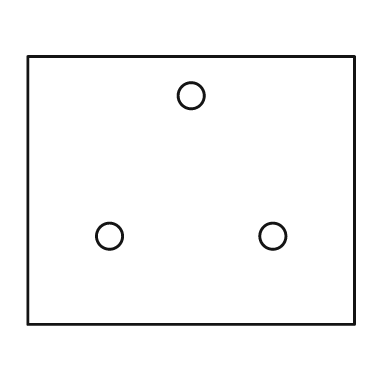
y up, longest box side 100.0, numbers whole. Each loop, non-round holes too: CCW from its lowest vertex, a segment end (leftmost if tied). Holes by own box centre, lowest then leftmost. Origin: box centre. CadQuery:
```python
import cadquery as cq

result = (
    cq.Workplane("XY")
    .moveTo(-50.0, -41.0)
    .lineTo(50.0, -41.0)
    .lineTo(50.0, 41.0)
    .lineTo(-50.0, 41.0)
    .close()
    .moveTo(-25.0, -14.0)
    .circle(4.0)
    .moveTo(25.0, -14.0)
    .circle(4.0)
    .moveTo(0.0, 29.0)
    .circle(4.0)
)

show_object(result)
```